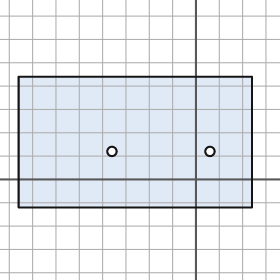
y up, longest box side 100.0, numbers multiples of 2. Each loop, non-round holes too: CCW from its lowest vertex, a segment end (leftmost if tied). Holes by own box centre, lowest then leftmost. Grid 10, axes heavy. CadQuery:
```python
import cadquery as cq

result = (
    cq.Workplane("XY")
    .moveTo(-76.0, -12.0)
    .lineTo(24.0, -12.0)
    .lineTo(24.0, 44.0)
    .lineTo(-76.0, 44.0)
    .close()
    .moveTo(-36.0, 12.0)
    .circle(2.0)
    .moveTo(6.0, 12.0)
    .circle(2.0)
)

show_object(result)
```